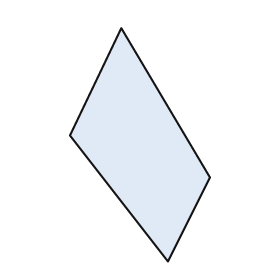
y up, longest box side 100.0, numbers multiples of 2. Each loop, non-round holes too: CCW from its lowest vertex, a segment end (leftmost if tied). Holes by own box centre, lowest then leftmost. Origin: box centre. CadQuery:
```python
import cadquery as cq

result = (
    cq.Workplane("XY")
    .moveTo(12.0, -50.0)
    .lineTo(30.0, -14.0)
    .lineTo(-8.0, 50.0)
    .lineTo(-30.0, 4.0)
    .close()
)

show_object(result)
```